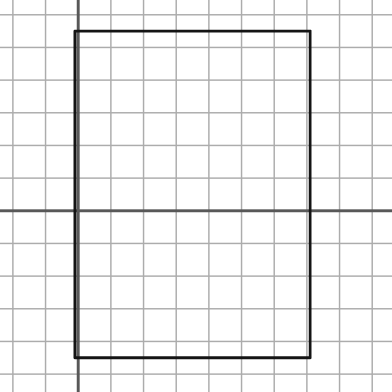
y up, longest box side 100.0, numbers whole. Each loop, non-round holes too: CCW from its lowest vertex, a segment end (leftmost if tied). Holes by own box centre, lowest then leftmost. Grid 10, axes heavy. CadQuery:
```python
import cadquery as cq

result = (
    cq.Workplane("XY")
    .moveTo(-1.0, -45.0)
    .lineTo(71.0, -45.0)
    .lineTo(71.0, 55.0)
    .lineTo(-1.0, 55.0)
    .close()
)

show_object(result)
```